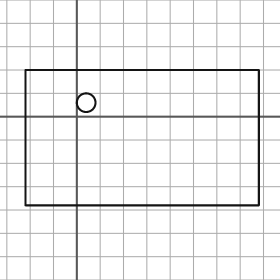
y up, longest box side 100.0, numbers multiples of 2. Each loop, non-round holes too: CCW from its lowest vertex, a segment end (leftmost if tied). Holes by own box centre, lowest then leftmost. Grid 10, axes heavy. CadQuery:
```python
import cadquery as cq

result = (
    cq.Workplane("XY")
    .moveTo(-22.0, -38.0)
    .lineTo(78.0, -38.0)
    .lineTo(78.0, 20.0)
    .lineTo(-22.0, 20.0)
    .close()
    .moveTo(4.0, 6.0)
    .circle(4.0)
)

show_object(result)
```